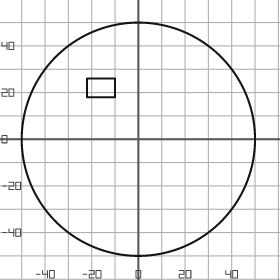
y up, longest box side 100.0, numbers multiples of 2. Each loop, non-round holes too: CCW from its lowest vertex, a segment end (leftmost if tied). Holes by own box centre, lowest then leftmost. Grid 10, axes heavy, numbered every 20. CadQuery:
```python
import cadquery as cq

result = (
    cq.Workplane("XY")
    .moveTo(0.0, 0.0)
    .circle(50.0)
    .moveTo(-22.0, 18.0)
    .lineTo(-10.0, 18.0)
    .lineTo(-10.0, 26.0)
    .lineTo(-22.0, 26.0)
    .close()
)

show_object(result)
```